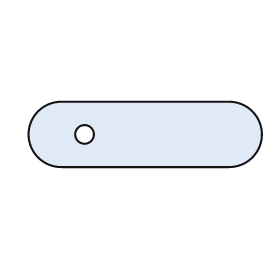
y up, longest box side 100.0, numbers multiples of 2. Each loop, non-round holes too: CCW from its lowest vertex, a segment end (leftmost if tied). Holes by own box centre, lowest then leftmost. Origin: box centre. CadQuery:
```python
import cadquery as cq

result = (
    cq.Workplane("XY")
    .moveTo(-36.0, -14.0)
    .lineTo(36.0, -14.0)
    .threePointArc((50.0, 0.0), (36.0, 14.0))
    .lineTo(-36.0, 14.0)
    .threePointArc((-50.0, 0.0), (-36.0, -14.0))
    .close()
    .moveTo(-26.0, 0.0)
    .circle(4.0)
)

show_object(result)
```